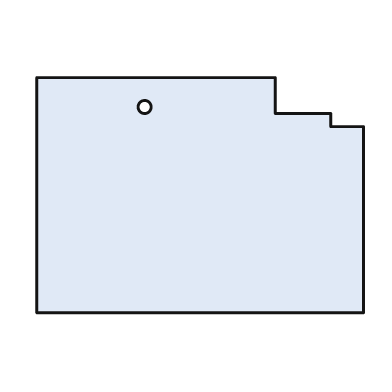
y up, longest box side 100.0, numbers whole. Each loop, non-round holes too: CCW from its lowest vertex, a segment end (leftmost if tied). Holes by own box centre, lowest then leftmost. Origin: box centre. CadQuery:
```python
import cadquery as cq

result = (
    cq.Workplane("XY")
    .moveTo(-50.0, -36.0)
    .lineTo(50.0, -36.0)
    .lineTo(50.0, 21.0)
    .lineTo(40.0, 21.0)
    .lineTo(40.0, 25.0)
    .lineTo(23.0, 25.0)
    .lineTo(23.0, 36.0)
    .lineTo(-50.0, 36.0)
    .close()
    .moveTo(-17.0, 27.0)
    .circle(2.0)
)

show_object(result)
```